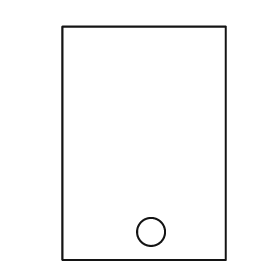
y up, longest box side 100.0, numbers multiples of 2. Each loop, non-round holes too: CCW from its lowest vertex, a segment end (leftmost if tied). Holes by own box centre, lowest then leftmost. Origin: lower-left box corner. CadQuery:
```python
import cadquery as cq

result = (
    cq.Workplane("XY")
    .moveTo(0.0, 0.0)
    .lineTo(70.0, 0.0)
    .lineTo(70.0, 100.0)
    .lineTo(0.0, 100.0)
    .close()
    .moveTo(38.0, 12.0)
    .circle(6.0)
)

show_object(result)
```